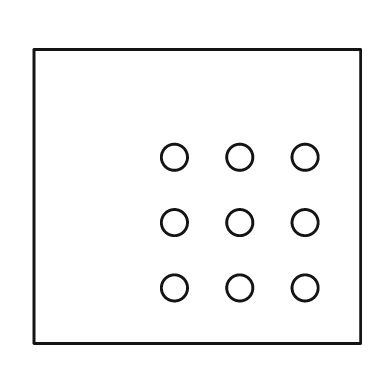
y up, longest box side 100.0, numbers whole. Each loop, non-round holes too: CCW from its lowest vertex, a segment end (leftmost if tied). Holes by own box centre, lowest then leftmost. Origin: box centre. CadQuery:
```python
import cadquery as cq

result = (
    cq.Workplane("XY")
    .moveTo(-50.0, -45.0)
    .lineTo(50.0, -45.0)
    .lineTo(50.0, 45.0)
    .lineTo(-50.0, 45.0)
    .close()
    .moveTo(-7.0, -28.0)
    .circle(4.0)
    .moveTo(13.0, -28.0)
    .circle(4.0)
    .moveTo(33.0, -28.0)
    .circle(4.0)
    .moveTo(-7.0, -8.0)
    .circle(4.0)
    .moveTo(13.0, -8.0)
    .circle(4.0)
    .moveTo(33.0, -8.0)
    .circle(4.0)
    .moveTo(-7.0, 12.0)
    .circle(4.0)
    .moveTo(13.0, 12.0)
    .circle(4.0)
    .moveTo(33.0, 12.0)
    .circle(4.0)
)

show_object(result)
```